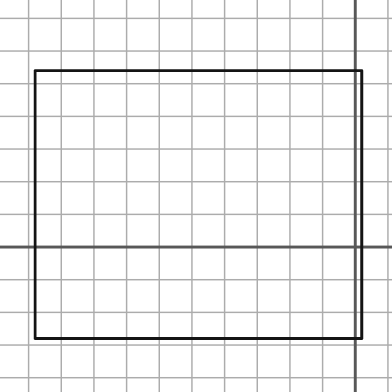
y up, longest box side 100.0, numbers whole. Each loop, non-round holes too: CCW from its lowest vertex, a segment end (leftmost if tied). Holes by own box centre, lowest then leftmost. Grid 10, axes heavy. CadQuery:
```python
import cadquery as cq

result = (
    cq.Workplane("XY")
    .moveTo(-98.0, -28.0)
    .lineTo(2.0, -28.0)
    .lineTo(2.0, 54.0)
    .lineTo(-98.0, 54.0)
    .close()
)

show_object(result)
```